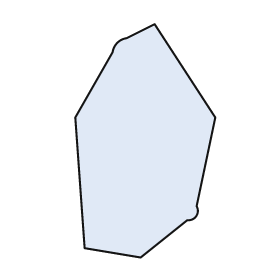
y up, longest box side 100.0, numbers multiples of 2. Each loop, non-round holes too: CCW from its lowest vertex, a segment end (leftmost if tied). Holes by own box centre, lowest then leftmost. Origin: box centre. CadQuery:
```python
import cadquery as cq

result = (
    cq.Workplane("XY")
    .moveTo(-2.0, -50.0)
    .lineTo(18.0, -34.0)
    .threePointArc((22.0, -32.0), (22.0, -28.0))
    .lineTo(30.0, 10.0)
    .lineTo(4.0, 50.0)
    .lineTo(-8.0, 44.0)
    .threePointArc((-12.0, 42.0), (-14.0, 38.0))
    .lineTo(-30.0, 10.0)
    .lineTo(-26.0, -46.0)
    .close()
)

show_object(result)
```